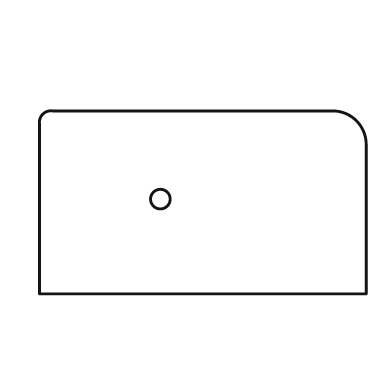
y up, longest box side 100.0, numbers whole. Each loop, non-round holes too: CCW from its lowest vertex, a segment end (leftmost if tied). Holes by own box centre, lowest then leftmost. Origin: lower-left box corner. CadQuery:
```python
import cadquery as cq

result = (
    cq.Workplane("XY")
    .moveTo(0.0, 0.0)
    .lineTo(100.0, 0.0)
    .lineTo(100.0, 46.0)
    .threePointArc((97.0, 53.0), (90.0, 56.0))
    .lineTo(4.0, 56.0)
    .threePointArc((1.0, 55.0), (0.0, 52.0))
    .close()
    .moveTo(37.0, 29.0)
    .circle(3.0)
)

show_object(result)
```